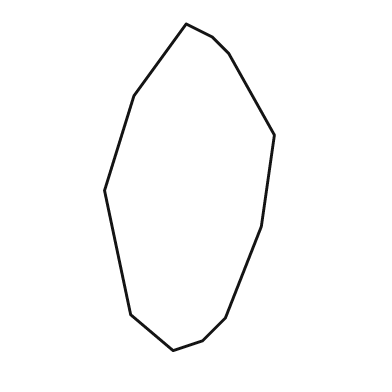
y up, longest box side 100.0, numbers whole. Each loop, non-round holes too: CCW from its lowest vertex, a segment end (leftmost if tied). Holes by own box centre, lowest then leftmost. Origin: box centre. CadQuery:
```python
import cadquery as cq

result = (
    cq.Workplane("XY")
    .moveTo(-5.0, -50.0)
    .lineTo(4.0, -47.0)
    .lineTo(11.0, -40.0)
    .lineTo(22.0, -12.0)
    .lineTo(26.0, 16.0)
    .lineTo(12.0, 41.0)
    .lineTo(7.0, 46.0)
    .lineTo(-1.0, 50.0)
    .lineTo(-17.0, 28.0)
    .lineTo(-26.0, -1.0)
    .lineTo(-18.0, -39.0)
    .close()
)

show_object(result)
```